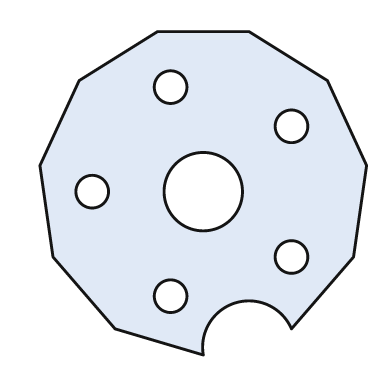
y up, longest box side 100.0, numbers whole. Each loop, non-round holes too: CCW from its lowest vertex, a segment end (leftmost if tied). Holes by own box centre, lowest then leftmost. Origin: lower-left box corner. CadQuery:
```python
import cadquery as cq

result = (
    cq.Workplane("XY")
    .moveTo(50.0, 0.0)
    .threePointArc((60.0, 16.0), (77.0, 8.0))
    .lineTo(96.0, 30.0)
    .lineTo(100.0, 58.0)
    .lineTo(88.0, 84.0)
    .lineTo(64.0, 99.0)
    .lineTo(36.0, 99.0)
    .lineTo(12.0, 84.0)
    .lineTo(0.0, 58.0)
    .lineTo(4.0, 30.0)
    .lineTo(23.0, 8.0)
    .close()
    .moveTo(40.0, 18.0)
    .circle(5.0)
    .moveTo(77.0, 30.0)
    .circle(5.0)
    .moveTo(16.0, 50.0)
    .circle(5.0)
    .moveTo(50.0, 50.0)
    .circle(12.0)
    .moveTo(77.0, 70.0)
    .circle(5.0)
    .moveTo(40.0, 82.0)
    .circle(5.0)
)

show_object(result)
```